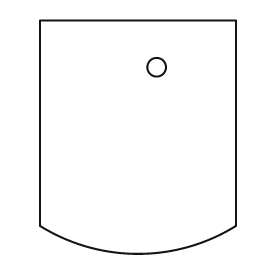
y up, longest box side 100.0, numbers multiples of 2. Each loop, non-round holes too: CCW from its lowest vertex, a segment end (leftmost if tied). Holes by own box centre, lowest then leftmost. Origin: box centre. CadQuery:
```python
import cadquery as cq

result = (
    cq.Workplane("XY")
    .moveTo(-42.0, -38.0)
    .threePointArc((0.0, -50.0), (42.0, -38.0))
    .lineTo(42.0, 50.0)
    .lineTo(-42.0, 50.0)
    .close()
    .moveTo(8.0, 30.0)
    .circle(4.0)
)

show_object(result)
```